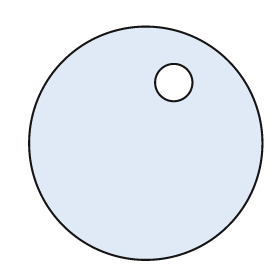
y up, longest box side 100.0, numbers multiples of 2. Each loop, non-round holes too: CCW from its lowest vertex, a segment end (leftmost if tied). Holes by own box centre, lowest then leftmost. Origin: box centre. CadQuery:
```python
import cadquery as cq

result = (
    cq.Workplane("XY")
    .moveTo(0.0, 0.0)
    .circle(50.0)
    .moveTo(12.0, 26.0)
    .circle(8.0)
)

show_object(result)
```